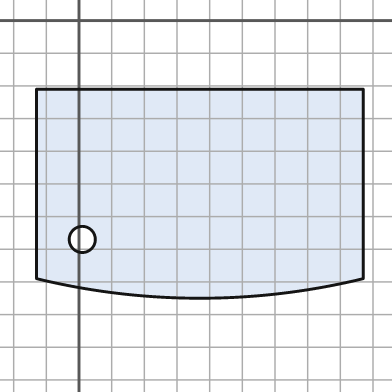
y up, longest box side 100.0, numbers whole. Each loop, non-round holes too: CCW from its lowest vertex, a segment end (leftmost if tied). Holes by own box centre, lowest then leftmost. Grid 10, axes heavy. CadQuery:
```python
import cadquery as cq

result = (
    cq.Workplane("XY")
    .moveTo(-13.0, -79.0)
    .threePointArc((37.0, -85.0), (87.0, -79.0))
    .lineTo(87.0, -21.0)
    .lineTo(-13.0, -21.0)
    .close()
    .moveTo(1.0, -67.0)
    .circle(4.0)
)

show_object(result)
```